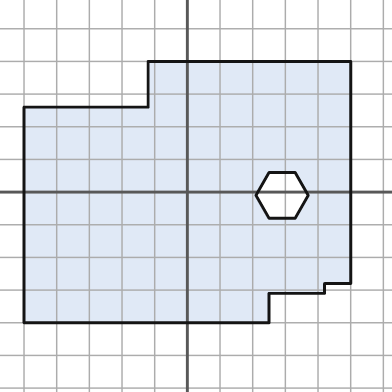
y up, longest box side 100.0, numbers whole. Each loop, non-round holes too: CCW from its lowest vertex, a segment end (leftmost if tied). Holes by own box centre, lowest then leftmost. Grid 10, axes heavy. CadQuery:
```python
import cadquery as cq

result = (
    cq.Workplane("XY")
    .moveTo(-50.0, -40.0)
    .lineTo(25.0, -40.0)
    .lineTo(25.0, -31.0)
    .lineTo(42.0, -31.0)
    .lineTo(42.0, -28.0)
    .lineTo(50.0, -28.0)
    .lineTo(50.0, 40.0)
    .lineTo(-12.0, 40.0)
    .lineTo(-12.0, 26.0)
    .lineTo(-50.0, 26.0)
    .close()
    .moveTo(25.0, -8.0)
    .lineTo(33.0, -8.0)
    .lineTo(37.0, -1.0)
    .lineTo(33.0, 6.0)
    .lineTo(25.0, 6.0)
    .lineTo(21.0, -1.0)
    .close()
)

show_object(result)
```